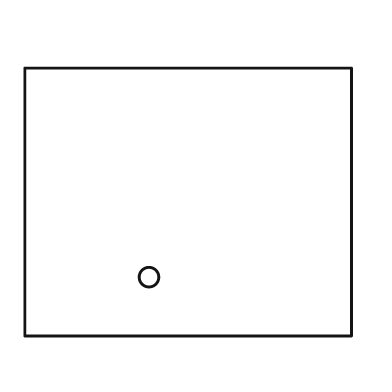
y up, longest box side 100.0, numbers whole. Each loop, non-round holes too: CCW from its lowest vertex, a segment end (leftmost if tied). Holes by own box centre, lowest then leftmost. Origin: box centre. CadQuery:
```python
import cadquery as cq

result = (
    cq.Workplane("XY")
    .moveTo(-50.0, -41.0)
    .lineTo(50.0, -41.0)
    .lineTo(50.0, 41.0)
    .lineTo(-50.0, 41.0)
    .close()
    .moveTo(-12.0, -23.0)
    .circle(3.0)
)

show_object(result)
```